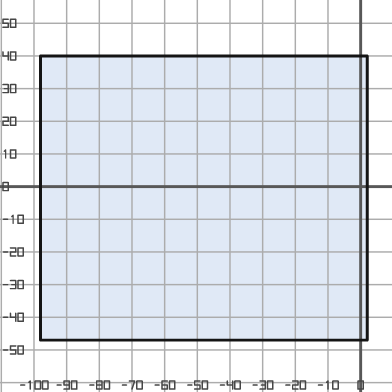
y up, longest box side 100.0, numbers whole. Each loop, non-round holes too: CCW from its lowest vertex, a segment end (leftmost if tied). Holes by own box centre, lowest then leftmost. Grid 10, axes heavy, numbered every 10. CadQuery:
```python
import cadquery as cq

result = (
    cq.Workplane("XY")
    .moveTo(-98.0, -47.0)
    .lineTo(2.0, -47.0)
    .lineTo(2.0, 40.0)
    .lineTo(-98.0, 40.0)
    .close()
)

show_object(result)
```